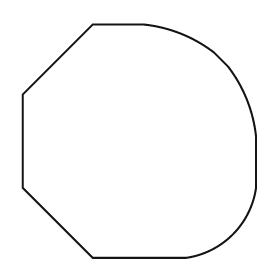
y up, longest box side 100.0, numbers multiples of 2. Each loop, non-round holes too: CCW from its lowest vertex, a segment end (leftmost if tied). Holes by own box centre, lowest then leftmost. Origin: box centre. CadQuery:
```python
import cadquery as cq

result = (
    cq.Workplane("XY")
    .moveTo(-20.0, -50.0)
    .lineTo(20.0, -50.0)
    .threePointArc((40.0, -40.0), (50.0, -20.0))
    .lineTo(50.0, 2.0)
    .threePointArc((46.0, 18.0), (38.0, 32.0))
    .lineTo(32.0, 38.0)
    .threePointArc((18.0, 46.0), (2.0, 50.0))
    .lineTo(-20.0, 50.0)
    .lineTo(-50.0, 20.0)
    .lineTo(-50.0, -20.0)
    .close()
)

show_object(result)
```